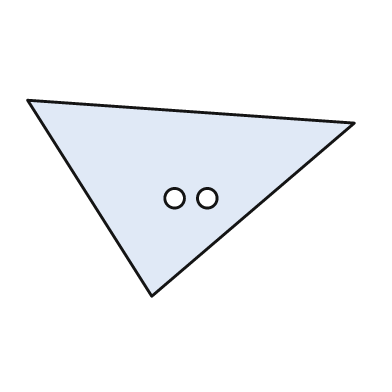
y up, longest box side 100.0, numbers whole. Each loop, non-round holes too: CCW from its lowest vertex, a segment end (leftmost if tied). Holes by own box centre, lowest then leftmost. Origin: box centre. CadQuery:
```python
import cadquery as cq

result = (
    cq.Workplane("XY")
    .moveTo(-12.0, -30.0)
    .lineTo(50.0, 23.0)
    .lineTo(-50.0, 30.0)
    .close()
    .moveTo(-5.0, 0.0)
    .circle(3.0)
    .moveTo(5.0, 0.0)
    .circle(3.0)
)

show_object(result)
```